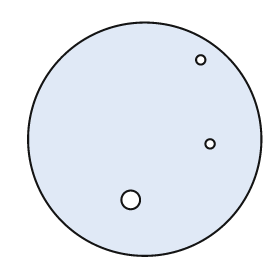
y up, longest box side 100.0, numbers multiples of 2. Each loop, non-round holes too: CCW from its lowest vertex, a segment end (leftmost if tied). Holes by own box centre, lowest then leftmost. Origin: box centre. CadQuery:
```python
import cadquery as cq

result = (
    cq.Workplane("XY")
    .moveTo(0.0, 0.0)
    .circle(50.0)
    .moveTo(-6.0, -26.0)
    .circle(4.0)
    .moveTo(28.0, -2.0)
    .circle(2.0)
    .moveTo(24.0, 34.0)
    .circle(2.0)
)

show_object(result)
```